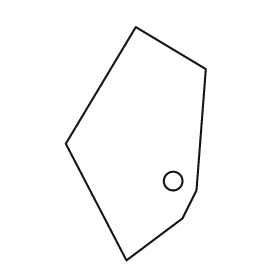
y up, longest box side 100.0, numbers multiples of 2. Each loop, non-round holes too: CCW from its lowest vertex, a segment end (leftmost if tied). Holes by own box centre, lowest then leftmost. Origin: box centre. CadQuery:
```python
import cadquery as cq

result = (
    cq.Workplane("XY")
    .moveTo(-4.0, -50.0)
    .lineTo(20.0, -32.0)
    .lineTo(26.0, -20.0)
    .lineTo(30.0, 32.0)
    .lineTo(0.0, 50.0)
    .lineTo(-30.0, 0.0)
    .close()
    .moveTo(16.0, -16.0)
    .circle(4.0)
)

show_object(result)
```